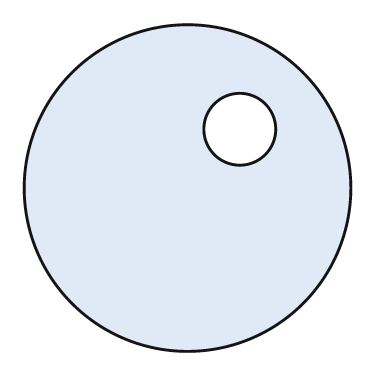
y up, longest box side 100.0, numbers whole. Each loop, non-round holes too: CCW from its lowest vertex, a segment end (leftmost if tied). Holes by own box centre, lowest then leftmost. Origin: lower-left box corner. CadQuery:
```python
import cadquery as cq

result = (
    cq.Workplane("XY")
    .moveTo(50.0, 50.0)
    .circle(50.0)
    .moveTo(66.0, 68.0)
    .circle(11.0)
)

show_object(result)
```